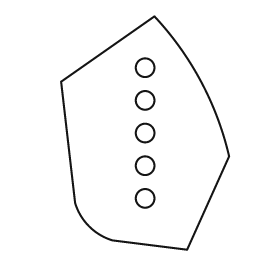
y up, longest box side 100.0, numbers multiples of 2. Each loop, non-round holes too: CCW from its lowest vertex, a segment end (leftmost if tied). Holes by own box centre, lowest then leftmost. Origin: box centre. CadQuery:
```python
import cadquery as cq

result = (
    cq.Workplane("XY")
    .moveTo(18.0, -50.0)
    .lineTo(36.0, -10.0)
    .threePointArc((24.0, 22.0), (4.0, 50.0))
    .lineTo(-36.0, 22.0)
    .lineTo(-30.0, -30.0)
    .threePointArc((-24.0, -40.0), (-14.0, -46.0))
    .close()
    .moveTo(0.0, -28.0)
    .circle(4.0)
    .moveTo(0.0, -14.0)
    .circle(4.0)
    .moveTo(0.0, 0.0)
    .circle(4.0)
    .moveTo(0.0, 14.0)
    .circle(4.0)
    .moveTo(0.0, 28.0)
    .circle(4.0)
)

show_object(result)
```